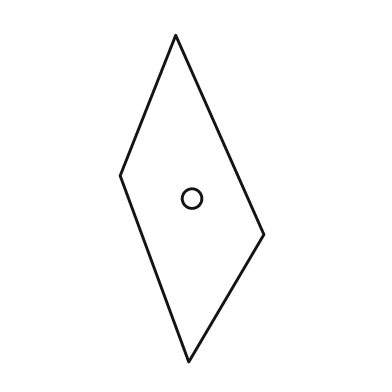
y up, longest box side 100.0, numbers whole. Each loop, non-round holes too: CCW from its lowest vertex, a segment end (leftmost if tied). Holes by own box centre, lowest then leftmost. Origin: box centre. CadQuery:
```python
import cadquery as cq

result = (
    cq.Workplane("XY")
    .moveTo(-1.0, -50.0)
    .lineTo(22.0, -11.0)
    .lineTo(-5.0, 50.0)
    .lineTo(-22.0, 7.0)
    .close()
    .moveTo(0.0, 0.0)
    .circle(3.0)
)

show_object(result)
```